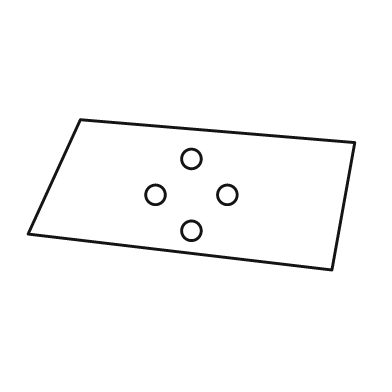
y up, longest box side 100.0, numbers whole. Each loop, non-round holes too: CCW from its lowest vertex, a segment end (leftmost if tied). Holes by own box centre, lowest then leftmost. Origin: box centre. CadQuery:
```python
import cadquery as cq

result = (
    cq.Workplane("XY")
    .moveTo(43.0, -23.0)
    .lineTo(50.0, 16.0)
    .lineTo(-34.0, 23.0)
    .lineTo(-50.0, -12.0)
    .close()
    .moveTo(0.0, -11.0)
    .circle(3.0)
    .moveTo(-11.0, 0.0)
    .circle(3.0)
    .moveTo(11.0, 0.0)
    .circle(3.0)
    .moveTo(0.0, 11.0)
    .circle(3.0)
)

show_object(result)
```